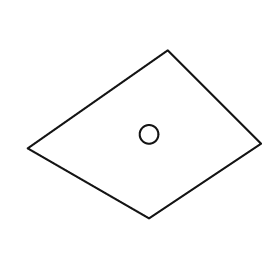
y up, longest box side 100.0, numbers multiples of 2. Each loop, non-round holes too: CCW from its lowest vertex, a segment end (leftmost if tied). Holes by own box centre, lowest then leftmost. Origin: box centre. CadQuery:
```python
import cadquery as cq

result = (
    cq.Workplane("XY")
    .moveTo(2.0, -36.0)
    .lineTo(50.0, -4.0)
    .lineTo(10.0, 36.0)
    .lineTo(-50.0, -6.0)
    .close()
    .moveTo(2.0, 0.0)
    .circle(4.0)
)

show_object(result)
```